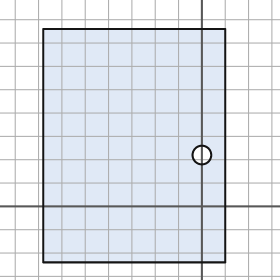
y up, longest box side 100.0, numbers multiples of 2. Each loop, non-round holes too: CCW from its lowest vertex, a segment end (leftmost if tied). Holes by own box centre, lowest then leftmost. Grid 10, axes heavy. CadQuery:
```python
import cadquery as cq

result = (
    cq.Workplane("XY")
    .moveTo(-68.0, -24.0)
    .lineTo(10.0, -24.0)
    .lineTo(10.0, 76.0)
    .lineTo(-68.0, 76.0)
    .close()
    .moveTo(0.0, 22.0)
    .circle(4.0)
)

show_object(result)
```